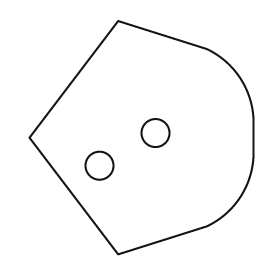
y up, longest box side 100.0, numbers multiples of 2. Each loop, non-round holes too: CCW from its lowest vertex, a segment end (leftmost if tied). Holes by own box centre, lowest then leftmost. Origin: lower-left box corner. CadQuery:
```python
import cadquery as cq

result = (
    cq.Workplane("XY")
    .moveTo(38.0, 0.0)
    .lineTo(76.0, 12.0)
    .threePointArc((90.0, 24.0), (96.0, 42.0))
    .lineTo(96.0, 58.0)
    .threePointArc((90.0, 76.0), (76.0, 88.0))
    .lineTo(38.0, 100.0)
    .lineTo(0.0, 50.0)
    .close()
    .moveTo(30.0, 38.0)
    .circle(6.0)
    .moveTo(54.0, 52.0)
    .circle(6.0)
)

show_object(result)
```